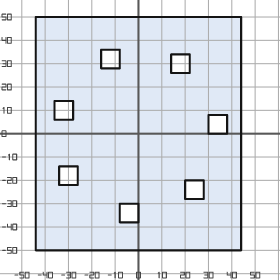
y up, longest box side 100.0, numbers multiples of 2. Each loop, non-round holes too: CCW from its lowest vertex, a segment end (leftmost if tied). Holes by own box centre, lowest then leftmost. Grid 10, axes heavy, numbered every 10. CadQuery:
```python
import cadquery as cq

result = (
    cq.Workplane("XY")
    .moveTo(-44.0, -50.0)
    .lineTo(44.0, -50.0)
    .lineTo(44.0, 50.0)
    .lineTo(-44.0, 50.0)
    .close()
    .moveTo(-8.0, -38.0)
    .lineTo(0.0, -38.0)
    .lineTo(0.0, -30.0)
    .lineTo(-8.0, -30.0)
    .close()
    .moveTo(20.0, -28.0)
    .lineTo(28.0, -28.0)
    .lineTo(28.0, -20.0)
    .lineTo(20.0, -20.0)
    .close()
    .moveTo(-34.0, -22.0)
    .lineTo(-26.0, -22.0)
    .lineTo(-26.0, -14.0)
    .lineTo(-34.0, -14.0)
    .close()
    .moveTo(30.0, 0.0)
    .lineTo(38.0, 0.0)
    .lineTo(38.0, 8.0)
    .lineTo(30.0, 8.0)
    .close()
    .moveTo(-36.0, 6.0)
    .lineTo(-28.0, 6.0)
    .lineTo(-28.0, 14.0)
    .lineTo(-36.0, 14.0)
    .close()
    .moveTo(14.0, 26.0)
    .lineTo(22.0, 26.0)
    .lineTo(22.0, 34.0)
    .lineTo(14.0, 34.0)
    .close()
    .moveTo(-16.0, 28.0)
    .lineTo(-8.0, 28.0)
    .lineTo(-8.0, 36.0)
    .lineTo(-16.0, 36.0)
    .close()
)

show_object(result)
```